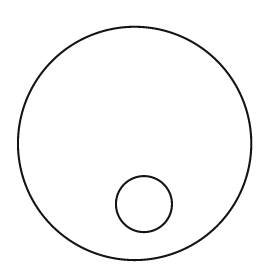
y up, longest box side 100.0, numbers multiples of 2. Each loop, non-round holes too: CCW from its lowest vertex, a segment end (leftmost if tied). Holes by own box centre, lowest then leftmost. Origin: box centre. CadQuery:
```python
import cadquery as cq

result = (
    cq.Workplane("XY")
    .moveTo(0.0, 0.0)
    .circle(50.0)
    .moveTo(4.0, -26.0)
    .circle(12.0)
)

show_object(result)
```